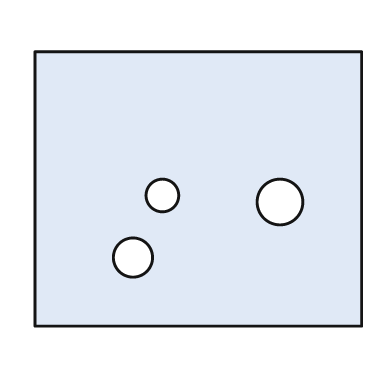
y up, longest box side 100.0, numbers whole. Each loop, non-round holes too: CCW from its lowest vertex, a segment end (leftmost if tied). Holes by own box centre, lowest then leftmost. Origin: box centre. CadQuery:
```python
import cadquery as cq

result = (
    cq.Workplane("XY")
    .moveTo(-50.0, -42.0)
    .lineTo(50.0, -42.0)
    .lineTo(50.0, 42.0)
    .lineTo(-50.0, 42.0)
    .close()
    .moveTo(-20.0, -21.0)
    .circle(6.0)
    .moveTo(25.0, -4.0)
    .circle(7.0)
    .moveTo(-11.0, -2.0)
    .circle(5.0)
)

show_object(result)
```